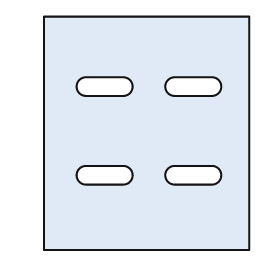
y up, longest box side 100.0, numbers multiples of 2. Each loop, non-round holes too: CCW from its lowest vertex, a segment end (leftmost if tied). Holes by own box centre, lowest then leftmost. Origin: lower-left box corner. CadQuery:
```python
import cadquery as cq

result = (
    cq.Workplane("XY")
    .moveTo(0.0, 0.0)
    .lineTo(88.0, 0.0)
    .lineTo(88.0, 100.0)
    .lineTo(0.0, 100.0)
    .close()
    .moveTo(18.0, 28.0)
    .lineTo(34.0, 28.0)
    .threePointArc((38.0, 32.0), (34.0, 36.0))
    .lineTo(18.0, 36.0)
    .threePointArc((14.0, 32.0), (18.0, 28.0))
    .close()
    .moveTo(56.0, 28.0)
    .lineTo(72.0, 28.0)
    .threePointArc((76.0, 32.0), (72.0, 36.0))
    .lineTo(56.0, 36.0)
    .threePointArc((52.0, 32.0), (56.0, 28.0))
    .close()
    .moveTo(18.0, 66.0)
    .lineTo(34.0, 66.0)
    .threePointArc((38.0, 70.0), (34.0, 74.0))
    .lineTo(18.0, 74.0)
    .threePointArc((14.0, 70.0), (18.0, 66.0))
    .close()
    .moveTo(56.0, 66.0)
    .lineTo(72.0, 66.0)
    .threePointArc((76.0, 70.0), (72.0, 74.0))
    .lineTo(56.0, 74.0)
    .threePointArc((52.0, 70.0), (56.0, 66.0))
    .close()
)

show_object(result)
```